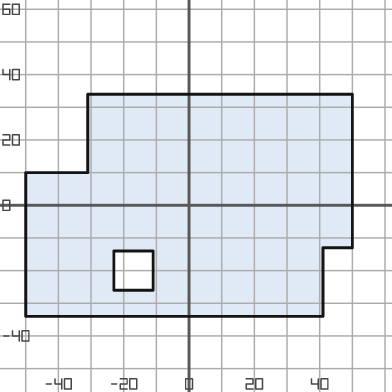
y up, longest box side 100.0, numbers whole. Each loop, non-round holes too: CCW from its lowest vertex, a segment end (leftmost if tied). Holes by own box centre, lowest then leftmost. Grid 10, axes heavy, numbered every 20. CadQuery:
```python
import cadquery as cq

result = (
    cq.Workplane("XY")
    .moveTo(-50.0, -34.0)
    .lineTo(41.0, -34.0)
    .lineTo(41.0, -13.0)
    .lineTo(50.0, -13.0)
    .lineTo(50.0, 34.0)
    .lineTo(-31.0, 34.0)
    .lineTo(-31.0, 10.0)
    .lineTo(-50.0, 10.0)
    .close()
    .moveTo(-23.0, -26.0)
    .lineTo(-11.0, -26.0)
    .lineTo(-11.0, -14.0)
    .lineTo(-23.0, -14.0)
    .close()
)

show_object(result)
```